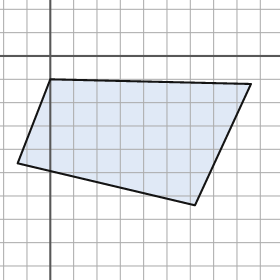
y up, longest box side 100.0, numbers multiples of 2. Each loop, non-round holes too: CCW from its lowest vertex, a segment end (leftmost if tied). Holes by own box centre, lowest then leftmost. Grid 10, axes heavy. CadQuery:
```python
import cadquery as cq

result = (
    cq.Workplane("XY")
    .moveTo(62.0, -64.0)
    .lineTo(86.0, -12.0)
    .lineTo(0.0, -10.0)
    .lineTo(-14.0, -46.0)
    .close()
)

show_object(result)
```